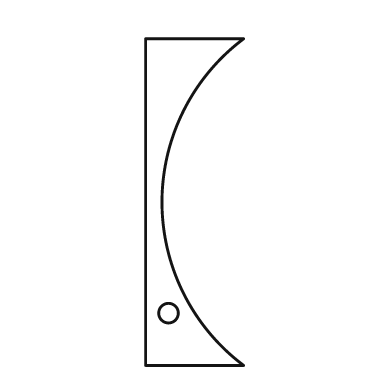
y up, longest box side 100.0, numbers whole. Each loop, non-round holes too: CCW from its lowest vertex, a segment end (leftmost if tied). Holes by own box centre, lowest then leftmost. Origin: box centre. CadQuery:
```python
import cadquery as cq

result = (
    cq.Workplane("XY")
    .moveTo(-15.0, -50.0)
    .lineTo(15.0, -50.0)
    .threePointArc((-10.0, 0.0), (15.0, 50.0))
    .lineTo(-15.0, 50.0)
    .close()
    .moveTo(-8.0, -34.0)
    .circle(3.0)
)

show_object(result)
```